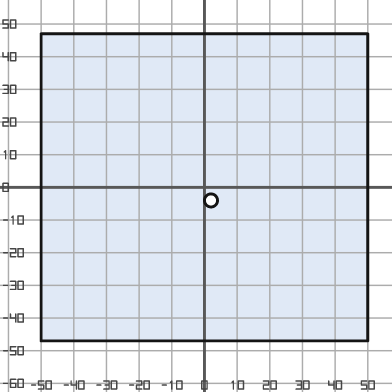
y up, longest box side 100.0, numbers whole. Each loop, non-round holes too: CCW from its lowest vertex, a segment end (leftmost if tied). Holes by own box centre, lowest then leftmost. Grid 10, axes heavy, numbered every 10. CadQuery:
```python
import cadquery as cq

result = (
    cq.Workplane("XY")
    .moveTo(-50.0, -47.0)
    .lineTo(50.0, -47.0)
    .lineTo(50.0, 47.0)
    .lineTo(-50.0, 47.0)
    .close()
    .moveTo(2.0, -4.0)
    .circle(2.0)
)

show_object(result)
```